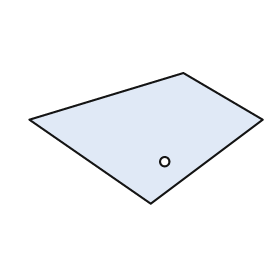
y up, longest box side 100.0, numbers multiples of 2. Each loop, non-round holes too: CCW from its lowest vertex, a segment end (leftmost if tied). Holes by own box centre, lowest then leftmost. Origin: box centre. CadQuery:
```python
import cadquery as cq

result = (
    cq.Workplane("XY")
    .moveTo(2.0, -28.0)
    .lineTo(50.0, 8.0)
    .lineTo(16.0, 28.0)
    .lineTo(-50.0, 8.0)
    .close()
    .moveTo(8.0, -10.0)
    .circle(2.0)
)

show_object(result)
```